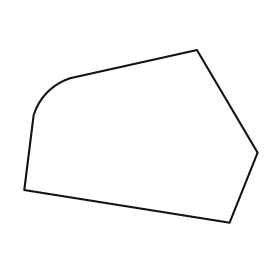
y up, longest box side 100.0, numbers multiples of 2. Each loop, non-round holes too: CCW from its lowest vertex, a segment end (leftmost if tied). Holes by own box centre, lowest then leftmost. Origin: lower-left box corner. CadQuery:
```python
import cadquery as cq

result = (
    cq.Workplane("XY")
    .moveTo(88.0, 0.0)
    .lineTo(100.0, 30.0)
    .lineTo(74.0, 74.0)
    .lineTo(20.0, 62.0)
    .threePointArc((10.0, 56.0), (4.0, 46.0))
    .lineTo(0.0, 14.0)
    .close()
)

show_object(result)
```